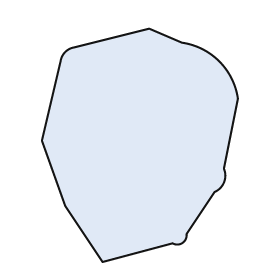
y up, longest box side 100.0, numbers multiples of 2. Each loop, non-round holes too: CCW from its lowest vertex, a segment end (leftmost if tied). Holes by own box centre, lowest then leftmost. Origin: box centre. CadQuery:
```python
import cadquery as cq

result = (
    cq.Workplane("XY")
    .moveTo(-16.0, -50.0)
    .lineTo(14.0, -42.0)
    .threePointArc((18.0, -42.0), (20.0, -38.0))
    .lineTo(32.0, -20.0)
    .threePointArc((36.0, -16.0), (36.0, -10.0))
    .lineTo(42.0, 20.0)
    .threePointArc((34.0, 36.0), (18.0, 44.0))
    .lineTo(4.0, 50.0)
    .lineTo(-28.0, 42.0)
    .threePointArc((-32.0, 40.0), (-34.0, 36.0))
    .lineTo(-42.0, 2.0)
    .lineTo(-32.0, -26.0)
    .close()
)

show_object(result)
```